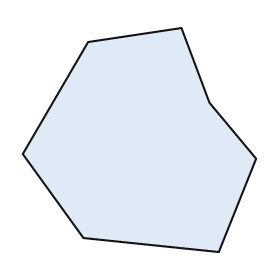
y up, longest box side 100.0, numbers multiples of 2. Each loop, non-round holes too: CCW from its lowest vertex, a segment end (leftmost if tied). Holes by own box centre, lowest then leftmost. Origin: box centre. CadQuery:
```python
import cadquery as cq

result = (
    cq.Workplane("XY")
    .moveTo(34.0, -48.0)
    .lineTo(50.0, -8.0)
    .lineTo(30.0, 16.0)
    .lineTo(18.0, 48.0)
    .lineTo(-22.0, 42.0)
    .lineTo(-50.0, -6.0)
    .lineTo(-24.0, -42.0)
    .close()
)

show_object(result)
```